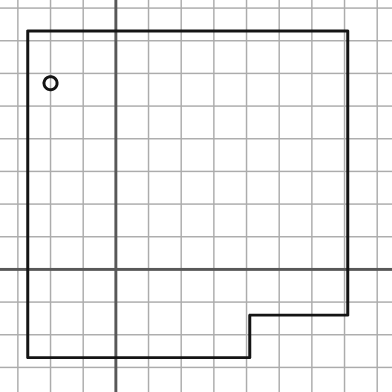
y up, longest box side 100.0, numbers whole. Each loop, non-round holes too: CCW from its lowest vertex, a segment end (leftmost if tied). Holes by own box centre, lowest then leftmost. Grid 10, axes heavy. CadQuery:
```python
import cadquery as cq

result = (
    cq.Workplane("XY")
    .moveTo(-27.0, -27.0)
    .lineTo(41.0, -27.0)
    .lineTo(41.0, -14.0)
    .lineTo(71.0, -14.0)
    .lineTo(71.0, 73.0)
    .lineTo(-27.0, 73.0)
    .close()
    .moveTo(-20.0, 57.0)
    .circle(2.0)
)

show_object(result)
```